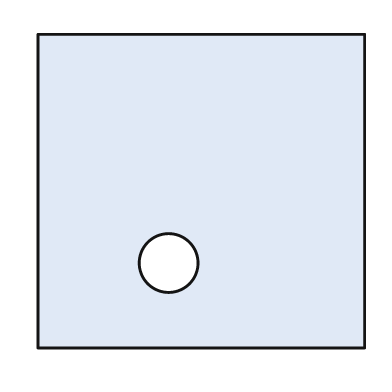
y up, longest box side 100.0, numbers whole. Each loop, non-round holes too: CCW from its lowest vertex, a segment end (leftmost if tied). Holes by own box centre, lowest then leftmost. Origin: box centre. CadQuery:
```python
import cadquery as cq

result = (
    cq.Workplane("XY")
    .moveTo(-50.0, -48.0)
    .lineTo(50.0, -48.0)
    .lineTo(50.0, 48.0)
    .lineTo(-50.0, 48.0)
    .close()
    .moveTo(-10.0, -22.0)
    .circle(9.0)
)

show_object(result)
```